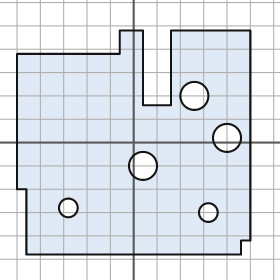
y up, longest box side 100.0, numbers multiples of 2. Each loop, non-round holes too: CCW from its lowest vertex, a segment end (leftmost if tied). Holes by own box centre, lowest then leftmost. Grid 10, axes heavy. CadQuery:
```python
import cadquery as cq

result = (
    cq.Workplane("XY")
    .moveTo(-46.0, -48.0)
    .lineTo(46.0, -48.0)
    .lineTo(46.0, -42.0)
    .lineTo(50.0, -42.0)
    .lineTo(50.0, 48.0)
    .lineTo(16.0, 48.0)
    .lineTo(16.0, 16.0)
    .lineTo(4.0, 16.0)
    .lineTo(4.0, 48.0)
    .lineTo(-6.0, 48.0)
    .lineTo(-6.0, 38.0)
    .lineTo(-50.0, 38.0)
    .lineTo(-50.0, -20.0)
    .lineTo(-46.0, -20.0)
    .close()
    .moveTo(32.0, -30.0)
    .circle(4.0)
    .moveTo(-28.0, -28.0)
    .circle(4.0)
    .moveTo(4.0, -10.0)
    .circle(6.0)
    .moveTo(40.0, 2.0)
    .circle(6.0)
    .moveTo(26.0, 20.0)
    .circle(6.0)
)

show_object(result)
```